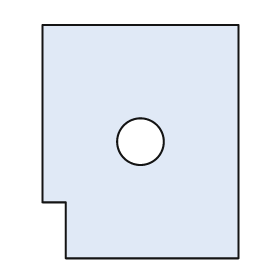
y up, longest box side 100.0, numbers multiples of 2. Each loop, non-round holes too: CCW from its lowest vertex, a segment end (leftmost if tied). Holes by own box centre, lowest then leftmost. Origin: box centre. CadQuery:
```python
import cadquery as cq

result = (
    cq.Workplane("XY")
    .moveTo(-32.0, -50.0)
    .lineTo(42.0, -50.0)
    .lineTo(42.0, 50.0)
    .lineTo(-42.0, 50.0)
    .lineTo(-42.0, -26.0)
    .lineTo(-32.0, -26.0)
    .close()
    .moveTo(0.0, 0.0)
    .circle(10.0)
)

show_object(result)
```